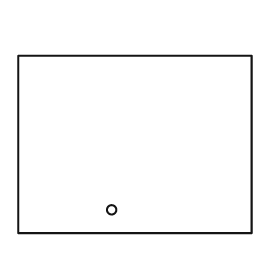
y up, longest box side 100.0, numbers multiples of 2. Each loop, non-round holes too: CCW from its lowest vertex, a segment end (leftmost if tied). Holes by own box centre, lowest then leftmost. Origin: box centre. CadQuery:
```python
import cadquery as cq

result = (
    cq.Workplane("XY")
    .moveTo(-50.0, -38.0)
    .lineTo(50.0, -38.0)
    .lineTo(50.0, 38.0)
    .lineTo(-50.0, 38.0)
    .close()
    .moveTo(-10.0, -28.0)
    .circle(2.0)
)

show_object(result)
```